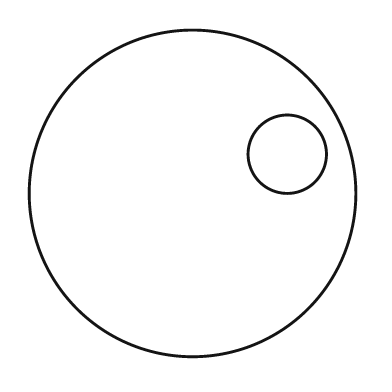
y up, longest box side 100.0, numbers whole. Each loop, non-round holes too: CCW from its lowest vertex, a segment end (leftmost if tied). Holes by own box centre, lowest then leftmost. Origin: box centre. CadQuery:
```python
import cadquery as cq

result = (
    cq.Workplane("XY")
    .moveTo(0.0, 0.0)
    .circle(50.0)
    .moveTo(29.0, 12.0)
    .circle(12.0)
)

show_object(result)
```